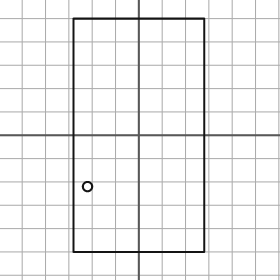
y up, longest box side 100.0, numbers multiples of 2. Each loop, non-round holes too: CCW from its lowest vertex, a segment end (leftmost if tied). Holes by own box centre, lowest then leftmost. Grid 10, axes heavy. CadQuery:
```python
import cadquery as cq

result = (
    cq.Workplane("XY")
    .moveTo(-28.0, -50.0)
    .lineTo(28.0, -50.0)
    .lineTo(28.0, 50.0)
    .lineTo(-28.0, 50.0)
    .close()
    .moveTo(-22.0, -22.0)
    .circle(2.0)
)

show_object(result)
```